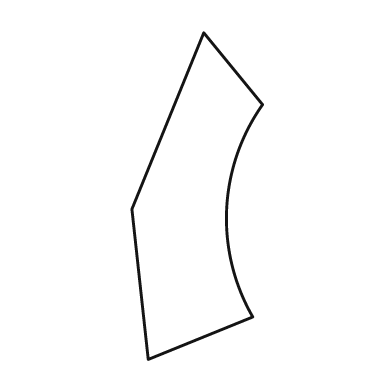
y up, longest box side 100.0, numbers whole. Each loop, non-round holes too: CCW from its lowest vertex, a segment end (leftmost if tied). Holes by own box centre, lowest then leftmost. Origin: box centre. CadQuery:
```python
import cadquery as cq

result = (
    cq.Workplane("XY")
    .moveTo(-15.0, -50.0)
    .lineTo(17.0, -37.0)
    .threePointArc((9.0, -4.0), (20.0, 28.0))
    .lineTo(2.0, 50.0)
    .lineTo(-20.0, -4.0)
    .close()
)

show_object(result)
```